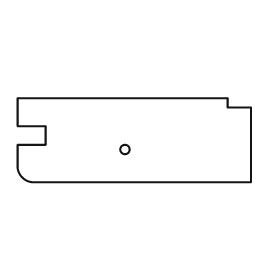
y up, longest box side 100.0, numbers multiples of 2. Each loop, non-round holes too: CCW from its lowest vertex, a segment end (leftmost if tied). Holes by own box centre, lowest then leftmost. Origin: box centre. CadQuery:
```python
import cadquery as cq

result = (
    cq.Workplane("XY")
    .moveTo(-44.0, -18.0)
    .lineTo(50.0, -18.0)
    .lineTo(50.0, 14.0)
    .lineTo(40.0, 14.0)
    .lineTo(40.0, 18.0)
    .lineTo(-50.0, 18.0)
    .lineTo(-50.0, 6.0)
    .lineTo(-38.0, 6.0)
    .lineTo(-38.0, -2.0)
    .lineTo(-50.0, -2.0)
    .lineTo(-50.0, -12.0)
    .threePointArc((-48.0, -16.0), (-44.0, -18.0))
    .close()
    .moveTo(-4.0, -4.0)
    .circle(2.0)
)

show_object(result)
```